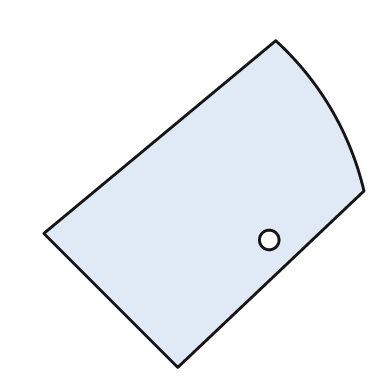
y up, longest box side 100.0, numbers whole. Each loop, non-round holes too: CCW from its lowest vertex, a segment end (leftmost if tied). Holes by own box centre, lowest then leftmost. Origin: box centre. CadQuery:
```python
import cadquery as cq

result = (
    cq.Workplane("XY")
    .moveTo(-8.0, -50.0)
    .lineTo(49.0, 4.0)
    .threePointArc((39.0, 29.0), (22.0, 50.0))
    .lineTo(-49.0, -9.0)
    .close()
    .moveTo(20.0, -11.0)
    .circle(3.0)
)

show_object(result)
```